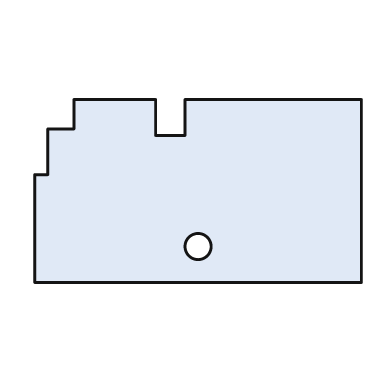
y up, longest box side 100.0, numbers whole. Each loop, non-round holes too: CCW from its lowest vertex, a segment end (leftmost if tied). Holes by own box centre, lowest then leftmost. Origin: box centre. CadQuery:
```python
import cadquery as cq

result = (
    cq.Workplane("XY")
    .moveTo(-50.0, -28.0)
    .lineTo(50.0, -28.0)
    .lineTo(50.0, 28.0)
    .lineTo(-4.0, 28.0)
    .lineTo(-4.0, 17.0)
    .lineTo(-13.0, 17.0)
    .lineTo(-13.0, 28.0)
    .lineTo(-38.0, 28.0)
    .lineTo(-38.0, 19.0)
    .lineTo(-46.0, 19.0)
    .lineTo(-46.0, 5.0)
    .lineTo(-50.0, 5.0)
    .close()
    .moveTo(0.0, -17.0)
    .circle(4.0)
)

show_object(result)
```